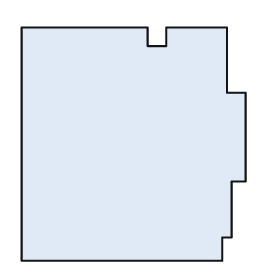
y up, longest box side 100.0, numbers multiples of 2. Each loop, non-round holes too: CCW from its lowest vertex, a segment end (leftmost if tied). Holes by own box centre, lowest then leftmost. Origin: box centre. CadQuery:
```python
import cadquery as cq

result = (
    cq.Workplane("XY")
    .moveTo(-48.0, -50.0)
    .lineTo(38.0, -50.0)
    .lineTo(38.0, -40.0)
    .lineTo(42.0, -40.0)
    .lineTo(42.0, -16.0)
    .lineTo(48.0, -16.0)
    .lineTo(48.0, 22.0)
    .lineTo(40.0, 22.0)
    .lineTo(40.0, 50.0)
    .lineTo(14.0, 50.0)
    .lineTo(14.0, 42.0)
    .lineTo(6.0, 42.0)
    .lineTo(6.0, 50.0)
    .lineTo(-48.0, 50.0)
    .close()
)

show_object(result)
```